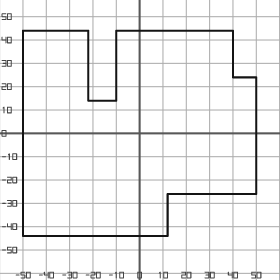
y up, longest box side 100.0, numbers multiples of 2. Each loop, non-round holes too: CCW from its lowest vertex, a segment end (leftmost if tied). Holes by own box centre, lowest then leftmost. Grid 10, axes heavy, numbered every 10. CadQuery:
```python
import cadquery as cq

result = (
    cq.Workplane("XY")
    .moveTo(-50.0, -44.0)
    .lineTo(12.0, -44.0)
    .lineTo(12.0, -26.0)
    .lineTo(50.0, -26.0)
    .lineTo(50.0, 24.0)
    .lineTo(40.0, 24.0)
    .lineTo(40.0, 44.0)
    .lineTo(-10.0, 44.0)
    .lineTo(-10.0, 14.0)
    .lineTo(-22.0, 14.0)
    .lineTo(-22.0, 44.0)
    .lineTo(-50.0, 44.0)
    .close()
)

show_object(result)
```